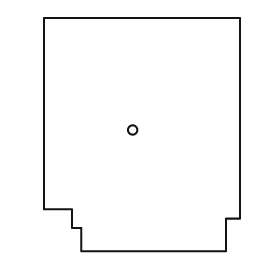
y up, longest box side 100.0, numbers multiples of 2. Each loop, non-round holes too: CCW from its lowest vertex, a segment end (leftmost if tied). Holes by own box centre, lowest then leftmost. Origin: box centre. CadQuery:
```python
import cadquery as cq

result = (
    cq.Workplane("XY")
    .moveTo(-26.0, -50.0)
    .lineTo(36.0, -50.0)
    .lineTo(36.0, -36.0)
    .lineTo(42.0, -36.0)
    .lineTo(42.0, 50.0)
    .lineTo(-42.0, 50.0)
    .lineTo(-42.0, -32.0)
    .lineTo(-30.0, -32.0)
    .lineTo(-30.0, -40.0)
    .lineTo(-26.0, -40.0)
    .close()
    .moveTo(-4.0, 2.0)
    .circle(2.0)
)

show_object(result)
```